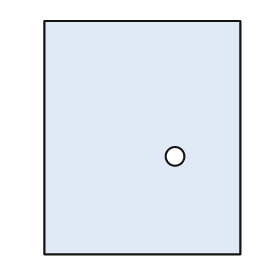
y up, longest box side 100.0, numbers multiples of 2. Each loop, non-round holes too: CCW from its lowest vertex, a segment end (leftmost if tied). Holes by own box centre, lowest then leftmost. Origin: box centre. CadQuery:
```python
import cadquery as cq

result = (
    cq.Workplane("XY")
    .moveTo(-42.0, -50.0)
    .lineTo(42.0, -50.0)
    .lineTo(42.0, 50.0)
    .lineTo(-42.0, 50.0)
    .close()
    .moveTo(14.0, -8.0)
    .circle(4.0)
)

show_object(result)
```